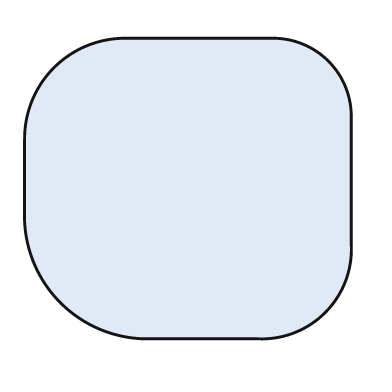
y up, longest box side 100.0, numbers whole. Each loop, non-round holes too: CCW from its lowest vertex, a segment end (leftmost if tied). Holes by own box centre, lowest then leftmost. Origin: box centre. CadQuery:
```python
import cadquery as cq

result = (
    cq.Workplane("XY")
    .moveTo(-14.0, -46.0)
    .lineTo(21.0, -46.0)
    .threePointArc((42.0, -38.0), (50.0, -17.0))
    .lineTo(50.0, 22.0)
    .threePointArc((43.0, 39.0), (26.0, 46.0))
    .lineTo(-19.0, 46.0)
    .threePointArc((-41.0, 37.0), (-50.0, 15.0))
    .lineTo(-50.0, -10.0)
    .threePointArc((-39.0, -35.0), (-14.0, -46.0))
    .close()
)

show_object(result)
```